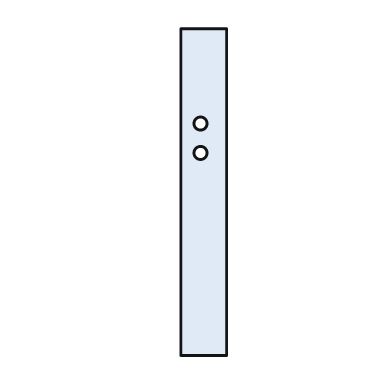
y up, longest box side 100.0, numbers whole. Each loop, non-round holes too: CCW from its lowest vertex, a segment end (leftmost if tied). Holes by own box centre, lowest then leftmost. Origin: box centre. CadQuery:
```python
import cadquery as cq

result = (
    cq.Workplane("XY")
    .moveTo(-7.0, -50.0)
    .lineTo(7.0, -50.0)
    .lineTo(7.0, 50.0)
    .lineTo(-7.0, 50.0)
    .close()
    .moveTo(-1.0, 12.0)
    .circle(2.0)
    .moveTo(-1.0, 21.0)
    .circle(2.0)
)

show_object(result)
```